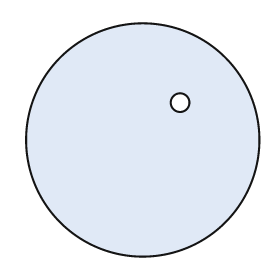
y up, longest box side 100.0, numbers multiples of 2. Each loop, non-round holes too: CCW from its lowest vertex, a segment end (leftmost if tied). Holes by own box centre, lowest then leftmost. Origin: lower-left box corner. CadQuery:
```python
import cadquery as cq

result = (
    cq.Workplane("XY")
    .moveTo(50.0, 50.0)
    .circle(50.0)
    .moveTo(66.0, 66.0)
    .circle(4.0)
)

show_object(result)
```